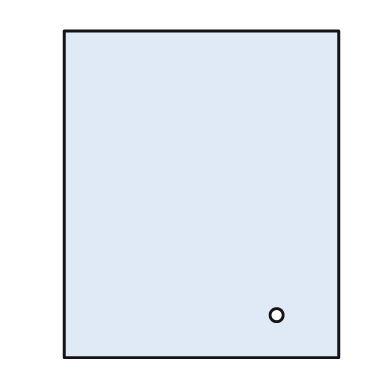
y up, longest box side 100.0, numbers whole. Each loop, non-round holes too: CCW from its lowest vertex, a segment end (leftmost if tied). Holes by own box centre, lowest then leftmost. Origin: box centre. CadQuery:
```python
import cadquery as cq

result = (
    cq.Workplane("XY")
    .moveTo(-42.0, -50.0)
    .lineTo(42.0, -50.0)
    .lineTo(42.0, 50.0)
    .lineTo(-42.0, 50.0)
    .close()
    .moveTo(23.0, -37.0)
    .circle(2.0)
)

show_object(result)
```